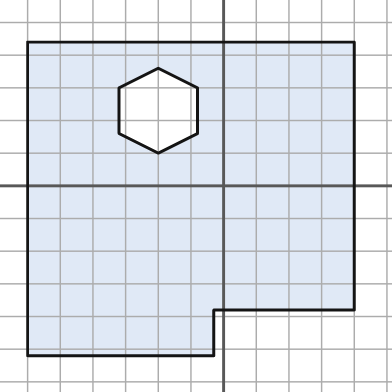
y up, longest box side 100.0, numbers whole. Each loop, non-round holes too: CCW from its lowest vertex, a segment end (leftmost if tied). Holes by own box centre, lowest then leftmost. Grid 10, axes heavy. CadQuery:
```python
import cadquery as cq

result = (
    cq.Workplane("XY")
    .moveTo(-60.0, -52.0)
    .lineTo(-3.0, -52.0)
    .lineTo(-3.0, -38.0)
    .lineTo(40.0, -38.0)
    .lineTo(40.0, 44.0)
    .lineTo(-60.0, 44.0)
    .close()
    .moveTo(-20.0, 10.0)
    .lineTo(-8.0, 16.0)
    .lineTo(-8.0, 30.0)
    .lineTo(-20.0, 36.0)
    .lineTo(-32.0, 30.0)
    .lineTo(-32.0, 16.0)
    .close()
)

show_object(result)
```